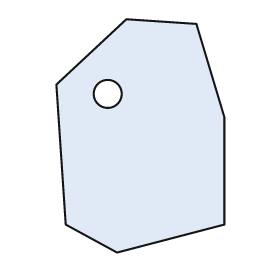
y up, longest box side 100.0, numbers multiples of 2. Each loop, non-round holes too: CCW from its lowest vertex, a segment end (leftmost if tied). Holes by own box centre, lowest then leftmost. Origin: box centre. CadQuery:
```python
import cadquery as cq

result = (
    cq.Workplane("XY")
    .moveTo(-10.0, -50.0)
    .lineTo(36.0, -38.0)
    .lineTo(36.0, 8.0)
    .lineTo(24.0, 48.0)
    .lineTo(-6.0, 50.0)
    .lineTo(-36.0, 22.0)
    .lineTo(-32.0, -38.0)
    .close()
    .moveTo(-14.0, 18.0)
    .circle(6.0)
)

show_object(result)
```